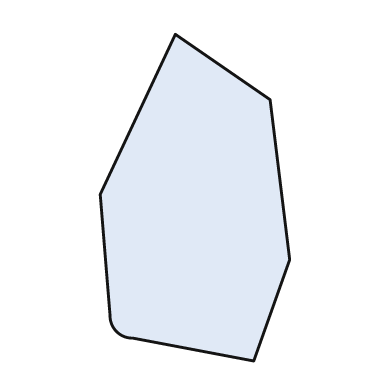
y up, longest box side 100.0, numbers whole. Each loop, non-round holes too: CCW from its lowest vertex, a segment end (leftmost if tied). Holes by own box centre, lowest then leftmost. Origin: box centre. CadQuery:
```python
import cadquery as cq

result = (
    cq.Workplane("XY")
    .moveTo(18.0, -50.0)
    .lineTo(29.0, -19.0)
    .lineTo(23.0, 30.0)
    .lineTo(-6.0, 50.0)
    .lineTo(-29.0, 1.0)
    .lineTo(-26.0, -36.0)
    .threePointArc((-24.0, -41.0), (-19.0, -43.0))
    .close()
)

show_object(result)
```